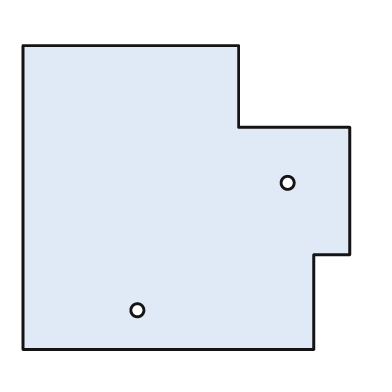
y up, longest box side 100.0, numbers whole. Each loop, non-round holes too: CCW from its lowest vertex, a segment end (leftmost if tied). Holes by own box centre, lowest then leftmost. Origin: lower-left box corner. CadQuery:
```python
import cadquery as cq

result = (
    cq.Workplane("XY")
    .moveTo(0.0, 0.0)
    .lineTo(89.0, 0.0)
    .lineTo(89.0, 29.0)
    .lineTo(100.0, 29.0)
    .lineTo(100.0, 68.0)
    .lineTo(66.0, 68.0)
    .lineTo(66.0, 93.0)
    .lineTo(0.0, 93.0)
    .close()
    .moveTo(35.0, 12.0)
    .circle(2.0)
    .moveTo(81.0, 51.0)
    .circle(2.0)
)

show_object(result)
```